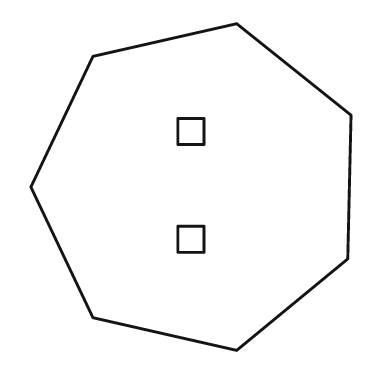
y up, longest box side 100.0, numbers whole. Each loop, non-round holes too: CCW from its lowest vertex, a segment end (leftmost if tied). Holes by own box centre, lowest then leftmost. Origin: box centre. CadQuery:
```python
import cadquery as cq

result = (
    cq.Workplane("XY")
    .moveTo(14.0, -50.0)
    .lineTo(48.0, -22.0)
    .lineTo(49.0, 22.0)
    .lineTo(14.0, 50.0)
    .lineTo(-30.0, 40.0)
    .lineTo(-49.0, 0.0)
    .lineTo(-30.0, -40.0)
    .close()
    .moveTo(-4.0, -20.0)
    .lineTo(4.0, -20.0)
    .lineTo(4.0, -12.0)
    .lineTo(-4.0, -12.0)
    .close()
    .moveTo(-4.0, 13.0)
    .lineTo(4.0, 13.0)
    .lineTo(4.0, 21.0)
    .lineTo(-4.0, 21.0)
    .close()
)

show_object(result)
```